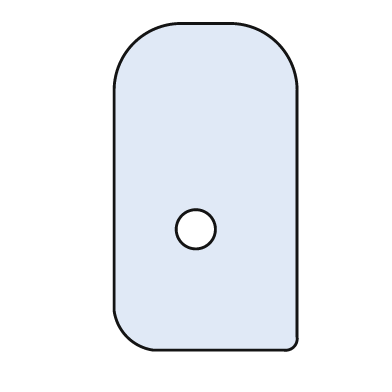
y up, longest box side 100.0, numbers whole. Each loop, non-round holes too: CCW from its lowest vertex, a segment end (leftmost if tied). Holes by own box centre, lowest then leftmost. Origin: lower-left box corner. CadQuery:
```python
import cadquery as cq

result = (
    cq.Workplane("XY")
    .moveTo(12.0, 0.0)
    .lineTo(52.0, 0.0)
    .threePointArc((55.0, 1.0), (56.0, 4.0))
    .lineTo(56.0, 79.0)
    .threePointArc((50.0, 94.0), (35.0, 100.0))
    .lineTo(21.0, 100.0)
    .threePointArc((6.0, 94.0), (0.0, 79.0))
    .lineTo(0.0, 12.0)
    .threePointArc((4.0, 4.0), (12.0, 0.0))
    .close()
    .moveTo(25.0, 37.0)
    .circle(6.0)
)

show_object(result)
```